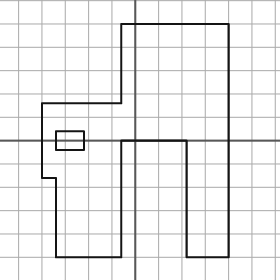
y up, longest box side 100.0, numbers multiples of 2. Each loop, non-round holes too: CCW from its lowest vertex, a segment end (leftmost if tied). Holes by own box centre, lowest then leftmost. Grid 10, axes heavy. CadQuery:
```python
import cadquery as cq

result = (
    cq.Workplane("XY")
    .moveTo(-34.0, -50.0)
    .lineTo(-6.0, -50.0)
    .lineTo(-6.0, 0.0)
    .lineTo(22.0, 0.0)
    .lineTo(22.0, -50.0)
    .lineTo(40.0, -50.0)
    .lineTo(40.0, 50.0)
    .lineTo(-6.0, 50.0)
    .lineTo(-6.0, 16.0)
    .lineTo(-40.0, 16.0)
    .lineTo(-40.0, -16.0)
    .lineTo(-34.0, -16.0)
    .close()
    .moveTo(-34.0, -4.0)
    .lineTo(-22.0, -4.0)
    .lineTo(-22.0, 4.0)
    .lineTo(-34.0, 4.0)
    .close()
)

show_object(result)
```